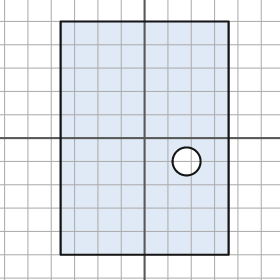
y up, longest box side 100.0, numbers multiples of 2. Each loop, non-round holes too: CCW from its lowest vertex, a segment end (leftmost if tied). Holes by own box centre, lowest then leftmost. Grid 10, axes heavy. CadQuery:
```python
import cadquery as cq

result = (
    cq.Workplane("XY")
    .moveTo(-36.0, -50.0)
    .lineTo(36.0, -50.0)
    .lineTo(36.0, 50.0)
    .lineTo(-36.0, 50.0)
    .close()
    .moveTo(18.0, -10.0)
    .circle(6.0)
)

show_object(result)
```